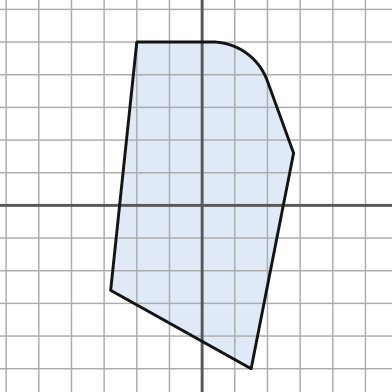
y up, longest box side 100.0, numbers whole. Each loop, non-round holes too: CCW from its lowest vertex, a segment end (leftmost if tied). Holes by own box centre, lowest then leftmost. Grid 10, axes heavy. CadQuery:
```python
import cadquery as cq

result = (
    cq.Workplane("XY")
    .moveTo(15.0, -50.0)
    .lineTo(28.0, 16.0)
    .lineTo(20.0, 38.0)
    .threePointArc((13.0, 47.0), (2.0, 50.0))
    .lineTo(-20.0, 50.0)
    .lineTo(-28.0, -26.0)
    .close()
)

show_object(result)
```